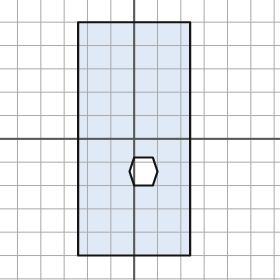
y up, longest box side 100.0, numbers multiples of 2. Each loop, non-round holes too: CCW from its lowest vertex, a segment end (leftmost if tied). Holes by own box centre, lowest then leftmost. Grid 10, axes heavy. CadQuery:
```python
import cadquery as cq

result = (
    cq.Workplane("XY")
    .moveTo(-24.0, -50.0)
    .lineTo(24.0, -50.0)
    .lineTo(24.0, 50.0)
    .lineTo(-24.0, 50.0)
    .close()
    .moveTo(0.0, -20.0)
    .lineTo(8.0, -20.0)
    .lineTo(10.0, -14.0)
    .lineTo(8.0, -8.0)
    .lineTo(0.0, -8.0)
    .lineTo(-2.0, -14.0)
    .close()
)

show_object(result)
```